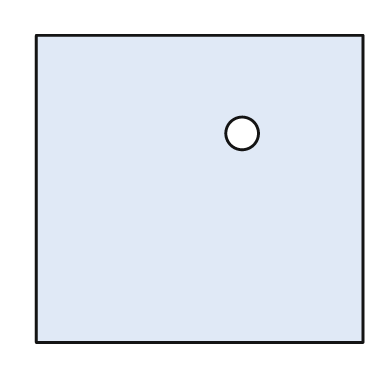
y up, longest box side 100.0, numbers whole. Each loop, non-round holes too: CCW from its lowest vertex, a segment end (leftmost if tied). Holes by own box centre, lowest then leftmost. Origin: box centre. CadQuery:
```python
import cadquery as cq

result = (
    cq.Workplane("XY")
    .moveTo(-50.0, -47.0)
    .lineTo(50.0, -47.0)
    .lineTo(50.0, 47.0)
    .lineTo(-50.0, 47.0)
    .close()
    .moveTo(13.0, 17.0)
    .circle(5.0)
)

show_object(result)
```